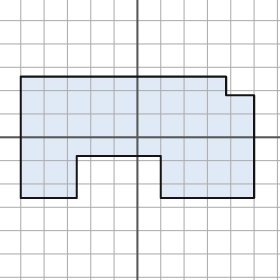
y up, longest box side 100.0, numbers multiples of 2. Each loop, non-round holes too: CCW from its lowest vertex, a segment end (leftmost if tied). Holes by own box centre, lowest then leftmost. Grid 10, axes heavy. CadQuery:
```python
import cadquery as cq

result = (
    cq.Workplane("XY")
    .moveTo(-50.0, -26.0)
    .lineTo(-26.0, -26.0)
    .lineTo(-26.0, -8.0)
    .lineTo(10.0, -8.0)
    .lineTo(10.0, -26.0)
    .lineTo(50.0, -26.0)
    .lineTo(50.0, 18.0)
    .lineTo(38.0, 18.0)
    .lineTo(38.0, 26.0)
    .lineTo(-50.0, 26.0)
    .close()
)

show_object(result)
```